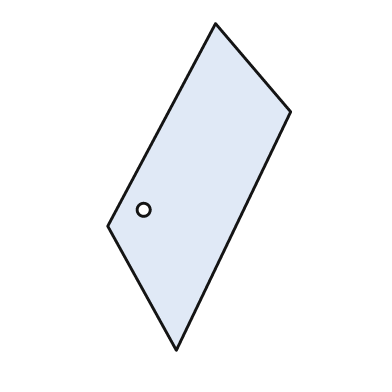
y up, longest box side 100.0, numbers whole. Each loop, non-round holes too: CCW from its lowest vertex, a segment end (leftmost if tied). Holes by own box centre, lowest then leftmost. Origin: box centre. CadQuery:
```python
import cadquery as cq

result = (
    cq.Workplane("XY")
    .moveTo(-7.0, -50.0)
    .lineTo(28.0, 23.0)
    .lineTo(5.0, 50.0)
    .lineTo(-28.0, -12.0)
    .close()
    .moveTo(-17.0, -7.0)
    .circle(2.0)
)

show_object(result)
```